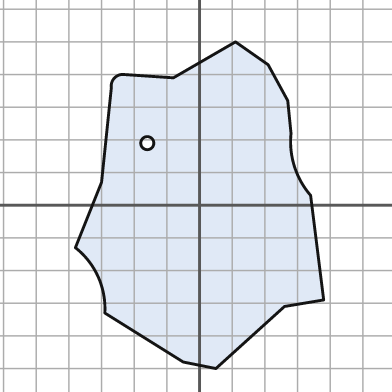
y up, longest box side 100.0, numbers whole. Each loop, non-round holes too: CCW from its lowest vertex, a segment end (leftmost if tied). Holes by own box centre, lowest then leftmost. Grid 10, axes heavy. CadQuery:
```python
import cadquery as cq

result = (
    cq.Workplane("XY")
    .moveTo(5.0, -50.0)
    .lineTo(26.0, -31.0)
    .lineTo(38.0, -29.0)
    .lineTo(34.0, 3.0)
    .threePointArc((29.0, 12.0), (28.0, 22.0))
    .lineTo(27.0, 32.0)
    .lineTo(21.0, 43.0)
    .lineTo(11.0, 50.0)
    .lineTo(-8.0, 39.0)
    .lineTo(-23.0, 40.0)
    .threePointArc((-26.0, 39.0), (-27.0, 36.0))
    .lineTo(-30.0, 7.0)
    .lineTo(-38.0, -13.0)
    .threePointArc((-31.0, -22.0), (-29.0, -33.0))
    .lineTo(-5.0, -48.0)
    .close()
    .moveTo(-16.0, 19.0)
    .circle(2.0)
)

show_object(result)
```